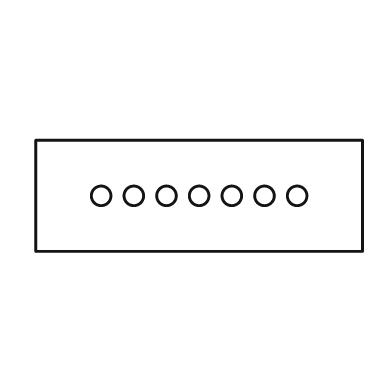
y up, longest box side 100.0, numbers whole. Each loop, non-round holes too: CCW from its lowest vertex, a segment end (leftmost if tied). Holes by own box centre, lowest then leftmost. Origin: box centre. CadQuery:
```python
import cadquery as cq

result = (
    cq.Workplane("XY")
    .moveTo(-50.0, -17.0)
    .lineTo(50.0, -17.0)
    .lineTo(50.0, 17.0)
    .lineTo(-50.0, 17.0)
    .close()
    .moveTo(-30.0, 0.0)
    .circle(3.0)
    .moveTo(-20.0, 0.0)
    .circle(3.0)
    .moveTo(-10.0, 0.0)
    .circle(3.0)
    .moveTo(0.0, 0.0)
    .circle(3.0)
    .moveTo(10.0, 0.0)
    .circle(3.0)
    .moveTo(20.0, 0.0)
    .circle(3.0)
    .moveTo(30.0, 0.0)
    .circle(3.0)
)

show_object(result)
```